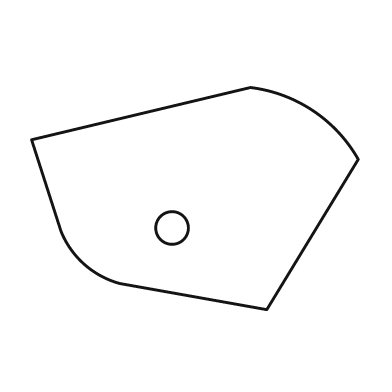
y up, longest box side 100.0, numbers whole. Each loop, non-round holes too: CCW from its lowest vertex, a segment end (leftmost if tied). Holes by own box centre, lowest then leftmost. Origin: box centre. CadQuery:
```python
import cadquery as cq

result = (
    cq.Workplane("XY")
    .moveTo(22.0, -34.0)
    .lineTo(50.0, 12.0)
    .threePointArc((36.0, 27.0), (17.0, 34.0))
    .lineTo(-50.0, 18.0)
    .lineTo(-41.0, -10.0)
    .threePointArc((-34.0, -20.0), (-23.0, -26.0))
    .close()
    .moveTo(-7.0, -9.0)
    .circle(5.0)
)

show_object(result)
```